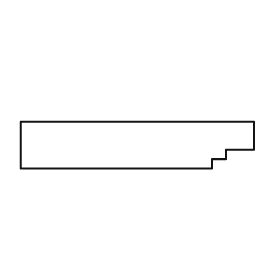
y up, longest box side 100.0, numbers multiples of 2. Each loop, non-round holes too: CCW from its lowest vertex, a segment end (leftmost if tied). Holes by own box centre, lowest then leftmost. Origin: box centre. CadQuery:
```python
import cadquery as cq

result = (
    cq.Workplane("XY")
    .moveTo(-50.0, -10.0)
    .lineTo(32.0, -10.0)
    .lineTo(32.0, -6.0)
    .lineTo(38.0, -6.0)
    .lineTo(38.0, -2.0)
    .lineTo(50.0, -2.0)
    .lineTo(50.0, 10.0)
    .lineTo(-50.0, 10.0)
    .close()
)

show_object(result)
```